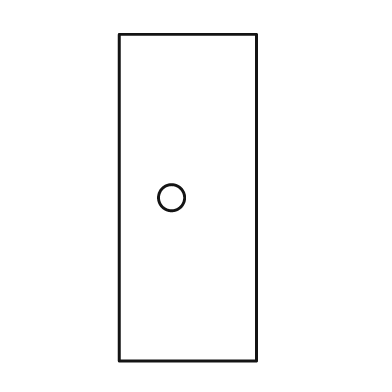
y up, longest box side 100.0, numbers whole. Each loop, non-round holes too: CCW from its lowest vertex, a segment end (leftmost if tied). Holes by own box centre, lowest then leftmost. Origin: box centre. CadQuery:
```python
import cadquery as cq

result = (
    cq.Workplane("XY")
    .moveTo(-21.0, -50.0)
    .lineTo(21.0, -50.0)
    .lineTo(21.0, 50.0)
    .lineTo(-21.0, 50.0)
    .close()
    .moveTo(-5.0, 0.0)
    .circle(4.0)
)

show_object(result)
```